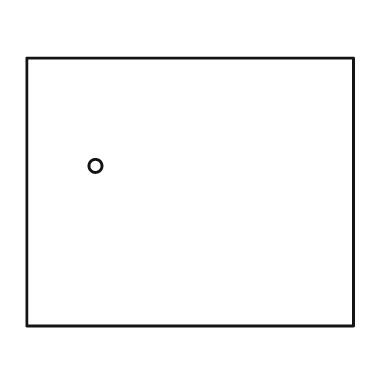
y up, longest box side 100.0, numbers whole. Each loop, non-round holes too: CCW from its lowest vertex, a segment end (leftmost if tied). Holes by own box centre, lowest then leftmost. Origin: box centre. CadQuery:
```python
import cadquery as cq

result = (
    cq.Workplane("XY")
    .moveTo(-50.0, -41.0)
    .lineTo(50.0, -41.0)
    .lineTo(50.0, 41.0)
    .lineTo(-50.0, 41.0)
    .close()
    .moveTo(-29.0, 8.0)
    .circle(2.0)
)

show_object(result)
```